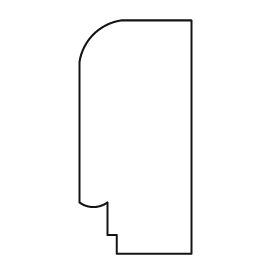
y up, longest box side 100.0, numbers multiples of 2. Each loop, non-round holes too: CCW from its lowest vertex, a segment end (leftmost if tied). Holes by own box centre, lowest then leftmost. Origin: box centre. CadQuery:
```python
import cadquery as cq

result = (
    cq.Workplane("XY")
    .moveTo(-8.0, -50.0)
    .lineTo(24.0, -50.0)
    .lineTo(24.0, 50.0)
    .lineTo(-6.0, 50.0)
    .threePointArc((-18.0, 44.0), (-24.0, 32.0))
    .lineTo(-24.0, -28.0)
    .threePointArc((-18.0, -30.0), (-12.0, -28.0))
    .lineTo(-12.0, -42.0)
    .lineTo(-8.0, -42.0)
    .close()
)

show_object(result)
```